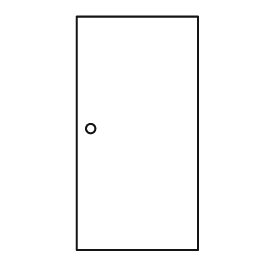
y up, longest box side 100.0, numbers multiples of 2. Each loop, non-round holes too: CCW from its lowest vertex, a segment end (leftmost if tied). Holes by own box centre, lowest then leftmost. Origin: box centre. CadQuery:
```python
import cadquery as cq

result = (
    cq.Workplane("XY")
    .moveTo(-26.0, -50.0)
    .lineTo(26.0, -50.0)
    .lineTo(26.0, 50.0)
    .lineTo(-26.0, 50.0)
    .close()
    .moveTo(-20.0, 2.0)
    .circle(2.0)
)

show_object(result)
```